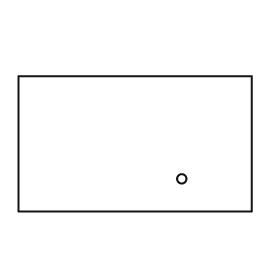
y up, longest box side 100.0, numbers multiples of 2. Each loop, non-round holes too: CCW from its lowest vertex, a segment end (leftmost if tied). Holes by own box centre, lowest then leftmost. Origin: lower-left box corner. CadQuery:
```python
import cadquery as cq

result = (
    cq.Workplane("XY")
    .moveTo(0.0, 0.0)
    .lineTo(100.0, 0.0)
    .lineTo(100.0, 58.0)
    .lineTo(0.0, 58.0)
    .close()
    .moveTo(70.0, 14.0)
    .circle(2.0)
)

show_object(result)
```